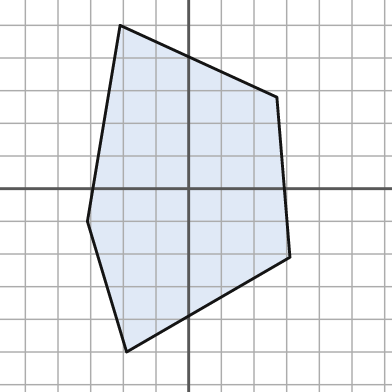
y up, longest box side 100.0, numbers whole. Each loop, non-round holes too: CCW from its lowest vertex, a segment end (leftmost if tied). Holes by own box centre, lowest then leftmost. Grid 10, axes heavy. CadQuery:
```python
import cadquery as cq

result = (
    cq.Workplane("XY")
    .moveTo(-19.0, -50.0)
    .lineTo(31.0, -21.0)
    .lineTo(27.0, 28.0)
    .lineTo(-21.0, 50.0)
    .lineTo(-31.0, -10.0)
    .close()
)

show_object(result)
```